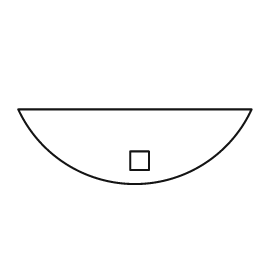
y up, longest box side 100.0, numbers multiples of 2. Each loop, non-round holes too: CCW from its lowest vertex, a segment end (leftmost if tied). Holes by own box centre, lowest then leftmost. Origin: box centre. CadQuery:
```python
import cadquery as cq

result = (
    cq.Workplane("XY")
    .moveTo(-50.0, 16.0)
    .threePointArc((0.0, -16.0), (50.0, 16.0))
    .close()
    .moveTo(-2.0, -10.0)
    .lineTo(6.0, -10.0)
    .lineTo(6.0, -2.0)
    .lineTo(-2.0, -2.0)
    .close()
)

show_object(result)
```